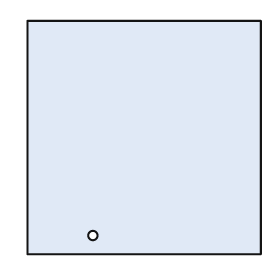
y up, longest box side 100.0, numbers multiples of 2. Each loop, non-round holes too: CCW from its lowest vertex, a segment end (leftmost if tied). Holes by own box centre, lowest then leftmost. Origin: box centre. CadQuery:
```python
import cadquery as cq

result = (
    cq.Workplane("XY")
    .moveTo(-50.0, -50.0)
    .lineTo(50.0, -50.0)
    .lineTo(50.0, 50.0)
    .lineTo(-50.0, 50.0)
    .close()
    .moveTo(-22.0, -42.0)
    .circle(2.0)
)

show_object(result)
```